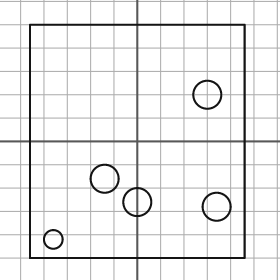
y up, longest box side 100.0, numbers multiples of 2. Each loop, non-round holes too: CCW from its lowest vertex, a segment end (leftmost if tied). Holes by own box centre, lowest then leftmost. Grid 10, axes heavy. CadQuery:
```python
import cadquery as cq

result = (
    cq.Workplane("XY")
    .moveTo(-46.0, -50.0)
    .lineTo(46.0, -50.0)
    .lineTo(46.0, 50.0)
    .lineTo(-46.0, 50.0)
    .close()
    .moveTo(-36.0, -42.0)
    .circle(4.0)
    .moveTo(34.0, -28.0)
    .circle(6.0)
    .moveTo(0.0, -26.0)
    .circle(6.0)
    .moveTo(-14.0, -16.0)
    .circle(6.0)
    .moveTo(30.0, 20.0)
    .circle(6.0)
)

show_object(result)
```